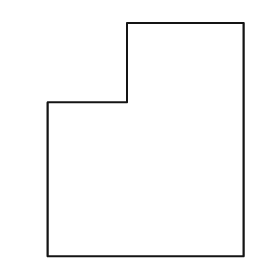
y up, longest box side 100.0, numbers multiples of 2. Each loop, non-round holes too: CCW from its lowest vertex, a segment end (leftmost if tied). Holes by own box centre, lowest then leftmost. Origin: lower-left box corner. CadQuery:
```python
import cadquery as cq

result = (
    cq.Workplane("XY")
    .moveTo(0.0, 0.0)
    .lineTo(84.0, 0.0)
    .lineTo(84.0, 100.0)
    .lineTo(34.0, 100.0)
    .lineTo(34.0, 66.0)
    .lineTo(0.0, 66.0)
    .close()
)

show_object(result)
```